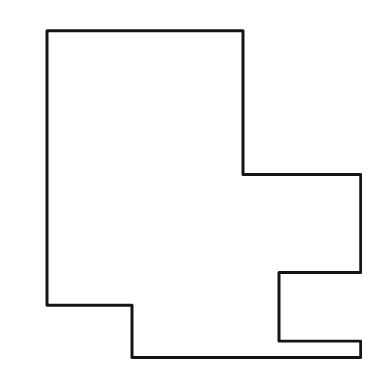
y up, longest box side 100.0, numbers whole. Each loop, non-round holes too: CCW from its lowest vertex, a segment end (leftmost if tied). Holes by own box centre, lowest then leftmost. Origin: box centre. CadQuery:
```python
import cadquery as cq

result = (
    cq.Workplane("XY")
    .moveTo(-22.0, -50.0)
    .lineTo(48.0, -50.0)
    .lineTo(48.0, -45.0)
    .lineTo(23.0, -45.0)
    .lineTo(23.0, -24.0)
    .lineTo(48.0, -24.0)
    .lineTo(48.0, 6.0)
    .lineTo(12.0, 6.0)
    .lineTo(12.0, 50.0)
    .lineTo(-48.0, 50.0)
    .lineTo(-48.0, -34.0)
    .lineTo(-22.0, -34.0)
    .close()
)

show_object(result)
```